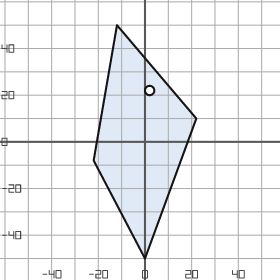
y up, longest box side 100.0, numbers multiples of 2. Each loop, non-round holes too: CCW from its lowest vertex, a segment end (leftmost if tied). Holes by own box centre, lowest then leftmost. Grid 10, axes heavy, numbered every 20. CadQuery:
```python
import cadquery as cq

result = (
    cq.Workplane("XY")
    .moveTo(0.0, -50.0)
    .lineTo(22.0, 10.0)
    .lineTo(-12.0, 50.0)
    .lineTo(-22.0, -8.0)
    .close()
    .moveTo(2.0, 22.0)
    .circle(2.0)
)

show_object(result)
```